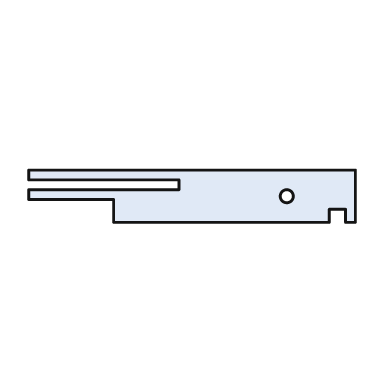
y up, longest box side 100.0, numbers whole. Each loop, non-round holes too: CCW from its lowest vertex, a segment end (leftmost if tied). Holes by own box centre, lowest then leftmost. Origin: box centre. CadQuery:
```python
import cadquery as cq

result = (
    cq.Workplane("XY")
    .moveTo(-24.0, -8.0)
    .lineTo(42.0, -8.0)
    .lineTo(42.0, -4.0)
    .lineTo(47.0, -4.0)
    .lineTo(47.0, -8.0)
    .lineTo(50.0, -8.0)
    .lineTo(50.0, 8.0)
    .lineTo(-50.0, 8.0)
    .lineTo(-50.0, 5.0)
    .lineTo(-4.0, 5.0)
    .lineTo(-4.0, 2.0)
    .lineTo(-50.0, 2.0)
    .lineTo(-50.0, -1.0)
    .lineTo(-24.0, -1.0)
    .close()
    .moveTo(29.0, 0.0)
    .circle(2.0)
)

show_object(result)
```